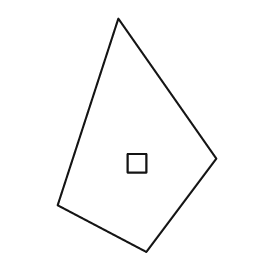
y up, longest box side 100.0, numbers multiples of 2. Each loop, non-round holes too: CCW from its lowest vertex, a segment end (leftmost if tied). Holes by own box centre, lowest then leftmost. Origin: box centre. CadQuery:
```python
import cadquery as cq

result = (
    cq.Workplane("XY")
    .moveTo(4.0, -50.0)
    .lineTo(34.0, -10.0)
    .lineTo(-8.0, 50.0)
    .lineTo(-34.0, -30.0)
    .close()
    .moveTo(-4.0, -16.0)
    .lineTo(4.0, -16.0)
    .lineTo(4.0, -8.0)
    .lineTo(-4.0, -8.0)
    .close()
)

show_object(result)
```